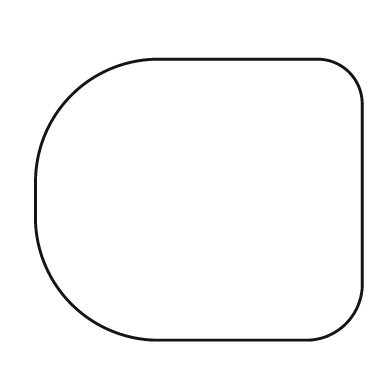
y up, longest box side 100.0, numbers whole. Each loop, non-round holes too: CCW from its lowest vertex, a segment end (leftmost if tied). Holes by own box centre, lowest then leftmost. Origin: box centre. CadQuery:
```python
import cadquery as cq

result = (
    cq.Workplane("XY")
    .moveTo(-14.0, -43.0)
    .lineTo(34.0, -43.0)
    .threePointArc((45.0, -38.0), (50.0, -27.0))
    .lineTo(50.0, 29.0)
    .threePointArc((46.0, 39.0), (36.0, 43.0))
    .lineTo(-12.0, 43.0)
    .threePointArc((-39.0, 32.0), (-50.0, 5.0))
    .lineTo(-50.0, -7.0)
    .threePointArc((-39.0, -32.0), (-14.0, -43.0))
    .close()
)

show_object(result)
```